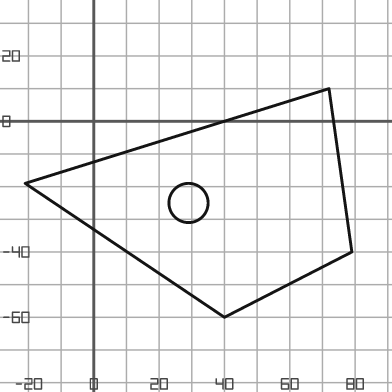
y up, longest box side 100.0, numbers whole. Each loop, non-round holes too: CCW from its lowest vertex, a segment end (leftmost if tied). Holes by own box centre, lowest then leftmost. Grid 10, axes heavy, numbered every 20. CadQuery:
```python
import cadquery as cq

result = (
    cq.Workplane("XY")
    .moveTo(40.0, -60.0)
    .lineTo(79.0, -40.0)
    .lineTo(72.0, 10.0)
    .lineTo(-21.0, -19.0)
    .close()
    .moveTo(29.0, -25.0)
    .circle(6.0)
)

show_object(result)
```